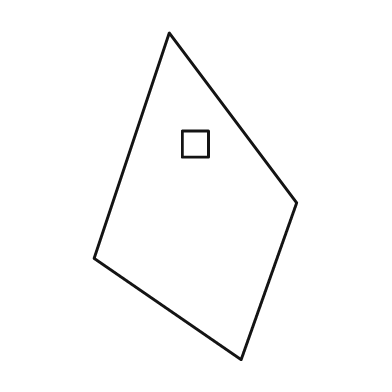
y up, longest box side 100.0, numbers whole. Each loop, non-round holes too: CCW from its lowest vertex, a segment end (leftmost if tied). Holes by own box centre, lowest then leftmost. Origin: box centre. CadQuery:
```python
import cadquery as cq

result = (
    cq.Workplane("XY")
    .moveTo(14.0, -50.0)
    .lineTo(31.0, -2.0)
    .lineTo(-8.0, 50.0)
    .lineTo(-31.0, -19.0)
    .close()
    .moveTo(-4.0, 12.0)
    .lineTo(4.0, 12.0)
    .lineTo(4.0, 20.0)
    .lineTo(-4.0, 20.0)
    .close()
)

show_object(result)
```